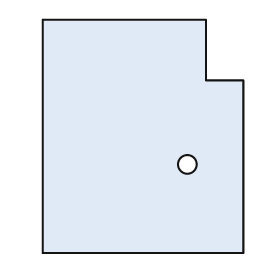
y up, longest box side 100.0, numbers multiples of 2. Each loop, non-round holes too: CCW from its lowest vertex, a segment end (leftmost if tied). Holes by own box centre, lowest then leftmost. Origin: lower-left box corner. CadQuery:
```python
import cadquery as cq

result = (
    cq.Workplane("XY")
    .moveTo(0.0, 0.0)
    .lineTo(86.0, 0.0)
    .lineTo(86.0, 74.0)
    .lineTo(70.0, 74.0)
    .lineTo(70.0, 100.0)
    .lineTo(0.0, 100.0)
    .close()
    .moveTo(62.0, 38.0)
    .circle(4.0)
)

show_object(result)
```